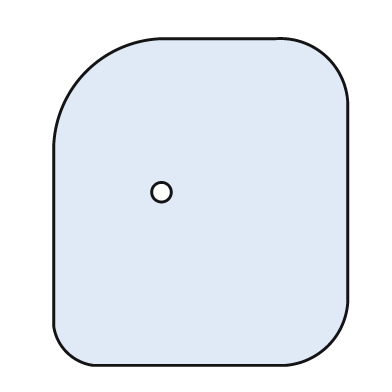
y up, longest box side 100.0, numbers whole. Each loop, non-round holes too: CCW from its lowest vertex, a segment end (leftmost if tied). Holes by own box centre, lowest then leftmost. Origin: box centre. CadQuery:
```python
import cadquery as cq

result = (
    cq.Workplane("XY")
    .moveTo(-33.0, -50.0)
    .lineTo(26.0, -50.0)
    .threePointArc((39.0, -44.0), (45.0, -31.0))
    .lineTo(45.0, 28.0)
    .threePointArc((39.0, 44.0), (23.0, 50.0))
    .lineTo(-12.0, 50.0)
    .threePointArc((-35.0, 40.0), (-45.0, 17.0))
    .lineTo(-45.0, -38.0)
    .threePointArc((-41.0, -46.0), (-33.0, -50.0))
    .close()
    .moveTo(-12.0, 3.0)
    .circle(3.0)
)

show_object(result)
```